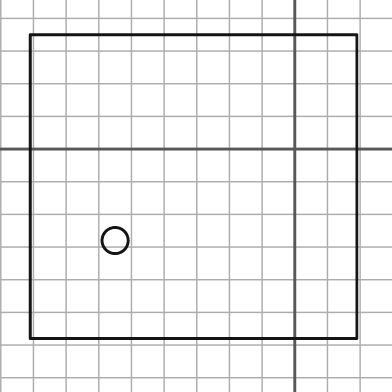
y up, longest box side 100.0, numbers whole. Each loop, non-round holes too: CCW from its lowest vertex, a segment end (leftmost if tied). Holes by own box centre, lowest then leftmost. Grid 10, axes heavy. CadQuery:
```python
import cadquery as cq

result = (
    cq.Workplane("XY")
    .moveTo(-81.0, -58.0)
    .lineTo(19.0, -58.0)
    .lineTo(19.0, 35.0)
    .lineTo(-81.0, 35.0)
    .close()
    .moveTo(-55.0, -28.0)
    .circle(4.0)
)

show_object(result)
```